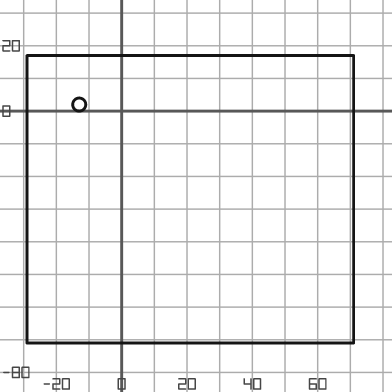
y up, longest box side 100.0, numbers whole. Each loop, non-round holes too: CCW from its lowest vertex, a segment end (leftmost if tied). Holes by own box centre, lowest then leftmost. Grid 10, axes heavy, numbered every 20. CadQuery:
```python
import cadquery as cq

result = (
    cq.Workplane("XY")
    .moveTo(-29.0, -71.0)
    .lineTo(71.0, -71.0)
    .lineTo(71.0, 17.0)
    .lineTo(-29.0, 17.0)
    .close()
    .moveTo(-13.0, 2.0)
    .circle(2.0)
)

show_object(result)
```